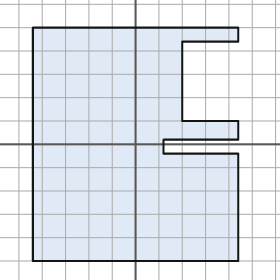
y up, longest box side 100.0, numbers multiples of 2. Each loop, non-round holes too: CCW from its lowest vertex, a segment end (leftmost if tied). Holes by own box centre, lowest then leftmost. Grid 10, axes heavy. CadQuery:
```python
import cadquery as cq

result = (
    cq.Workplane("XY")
    .moveTo(-44.0, -50.0)
    .lineTo(44.0, -50.0)
    .lineTo(44.0, -4.0)
    .lineTo(12.0, -4.0)
    .lineTo(12.0, 2.0)
    .lineTo(44.0, 2.0)
    .lineTo(44.0, 10.0)
    .lineTo(20.0, 10.0)
    .lineTo(20.0, 44.0)
    .lineTo(44.0, 44.0)
    .lineTo(44.0, 50.0)
    .lineTo(-44.0, 50.0)
    .close()
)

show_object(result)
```